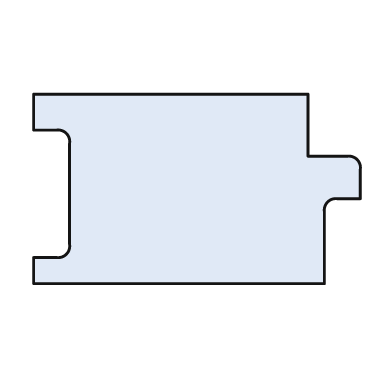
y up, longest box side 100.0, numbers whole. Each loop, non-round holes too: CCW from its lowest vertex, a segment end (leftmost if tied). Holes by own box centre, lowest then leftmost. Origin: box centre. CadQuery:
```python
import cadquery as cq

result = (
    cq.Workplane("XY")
    .moveTo(-50.0, -29.0)
    .lineTo(39.0, -29.0)
    .lineTo(39.0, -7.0)
    .threePointArc((40.0, -4.0), (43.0, -3.0))
    .lineTo(50.0, -3.0)
    .lineTo(50.0, 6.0)
    .threePointArc((49.0, 9.0), (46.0, 10.0))
    .lineTo(34.0, 10.0)
    .lineTo(34.0, 29.0)
    .lineTo(-50.0, 29.0)
    .lineTo(-50.0, 18.0)
    .lineTo(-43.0, 18.0)
    .threePointArc((-40.0, 17.0), (-39.0, 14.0))
    .lineTo(-39.0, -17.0)
    .threePointArc((-40.0, -20.0), (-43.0, -21.0))
    .lineTo(-50.0, -21.0)
    .close()
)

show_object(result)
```